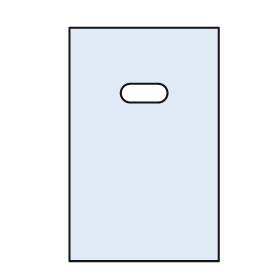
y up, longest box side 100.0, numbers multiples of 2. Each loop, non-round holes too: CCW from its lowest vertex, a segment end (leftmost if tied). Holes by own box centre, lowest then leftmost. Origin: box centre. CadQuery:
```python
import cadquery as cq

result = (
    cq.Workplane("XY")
    .moveTo(-32.0, -50.0)
    .lineTo(32.0, -50.0)
    .lineTo(32.0, 50.0)
    .lineTo(-32.0, 50.0)
    .close()
    .moveTo(-6.0, 18.0)
    .lineTo(6.0, 18.0)
    .threePointArc((10.0, 22.0), (6.0, 26.0))
    .lineTo(-6.0, 26.0)
    .threePointArc((-10.0, 22.0), (-6.0, 18.0))
    .close()
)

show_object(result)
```